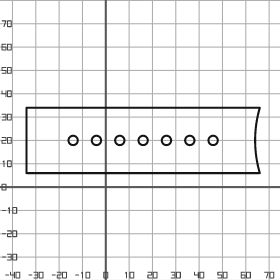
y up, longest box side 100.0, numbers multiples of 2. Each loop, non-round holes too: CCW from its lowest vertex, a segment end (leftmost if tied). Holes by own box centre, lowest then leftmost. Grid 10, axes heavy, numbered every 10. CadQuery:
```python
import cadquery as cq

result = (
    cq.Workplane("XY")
    .moveTo(-34.0, 6.0)
    .lineTo(66.0, 6.0)
    .threePointArc((64.0, 20.0), (66.0, 34.0))
    .lineTo(-34.0, 34.0)
    .close()
    .moveTo(-14.0, 20.0)
    .circle(2.0)
    .moveTo(-4.0, 20.0)
    .circle(2.0)
    .moveTo(6.0, 20.0)
    .circle(2.0)
    .moveTo(16.0, 20.0)
    .circle(2.0)
    .moveTo(26.0, 20.0)
    .circle(2.0)
    .moveTo(36.0, 20.0)
    .circle(2.0)
    .moveTo(46.0, 20.0)
    .circle(2.0)
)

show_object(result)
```